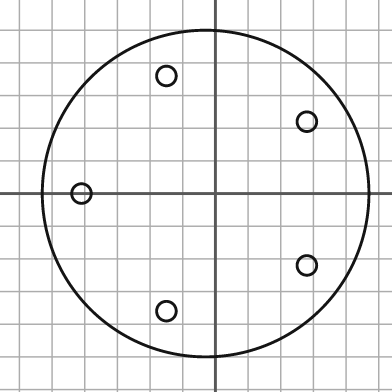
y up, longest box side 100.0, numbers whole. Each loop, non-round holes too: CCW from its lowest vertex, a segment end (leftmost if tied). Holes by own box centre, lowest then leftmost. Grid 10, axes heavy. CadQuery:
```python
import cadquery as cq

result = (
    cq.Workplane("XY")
    .moveTo(-3.0, 0.0)
    .circle(50.0)
    .moveTo(-15.0, -36.0)
    .circle(3.0)
    .moveTo(28.0, -22.0)
    .circle(3.0)
    .moveTo(-41.0, 0.0)
    .circle(3.0)
    .moveTo(28.0, 22.0)
    .circle(3.0)
    .moveTo(-15.0, 36.0)
    .circle(3.0)
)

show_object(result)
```